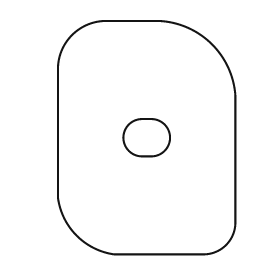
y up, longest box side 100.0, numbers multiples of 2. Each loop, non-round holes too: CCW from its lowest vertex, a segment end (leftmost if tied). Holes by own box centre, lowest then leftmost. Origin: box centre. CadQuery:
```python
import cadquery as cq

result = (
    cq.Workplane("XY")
    .moveTo(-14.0, -50.0)
    .lineTo(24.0, -50.0)
    .threePointArc((34.0, -46.0), (38.0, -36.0))
    .lineTo(38.0, 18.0)
    .threePointArc((28.0, 40.0), (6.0, 50.0))
    .lineTo(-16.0, 50.0)
    .threePointArc((-32.0, 44.0), (-38.0, 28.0))
    .lineTo(-38.0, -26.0)
    .threePointArc((-30.0, -42.0), (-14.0, -50.0))
    .close()
    .moveTo(-2.0, -8.0)
    .lineTo(2.0, -8.0)
    .threePointArc((10.0, 0.0), (2.0, 8.0))
    .lineTo(-2.0, 8.0)
    .threePointArc((-10.0, 0.0), (-2.0, -8.0))
    .close()
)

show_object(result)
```